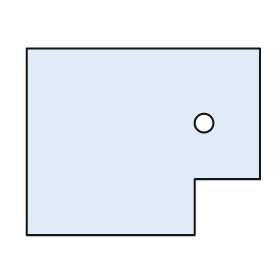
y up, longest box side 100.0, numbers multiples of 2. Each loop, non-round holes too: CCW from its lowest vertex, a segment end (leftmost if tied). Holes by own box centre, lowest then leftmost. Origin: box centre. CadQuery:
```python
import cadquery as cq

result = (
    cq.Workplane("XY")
    .moveTo(-50.0, -40.0)
    .lineTo(22.0, -40.0)
    .lineTo(22.0, -16.0)
    .lineTo(50.0, -16.0)
    .lineTo(50.0, 40.0)
    .lineTo(-50.0, 40.0)
    .close()
    .moveTo(26.0, 8.0)
    .circle(4.0)
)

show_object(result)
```